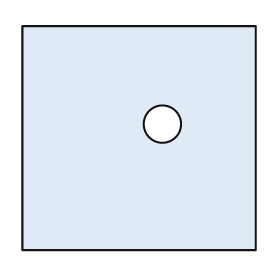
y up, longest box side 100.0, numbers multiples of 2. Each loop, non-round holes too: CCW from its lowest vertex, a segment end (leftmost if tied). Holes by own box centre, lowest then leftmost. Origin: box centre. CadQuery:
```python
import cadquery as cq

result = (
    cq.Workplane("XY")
    .moveTo(-50.0, -48.0)
    .lineTo(50.0, -48.0)
    .lineTo(50.0, 48.0)
    .lineTo(-50.0, 48.0)
    .close()
    .moveTo(10.0, 6.0)
    .circle(8.0)
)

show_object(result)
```